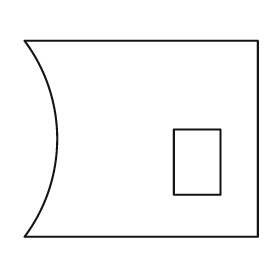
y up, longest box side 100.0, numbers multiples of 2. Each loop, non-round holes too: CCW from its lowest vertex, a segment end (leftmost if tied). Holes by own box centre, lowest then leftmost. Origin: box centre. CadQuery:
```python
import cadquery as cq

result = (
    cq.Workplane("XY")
    .moveTo(-50.0, -42.0)
    .lineTo(50.0, -42.0)
    .lineTo(50.0, 42.0)
    .lineTo(-50.0, 42.0)
    .threePointArc((-36.0, 0.0), (-50.0, -42.0))
    .close()
    .moveTo(14.0, -24.0)
    .lineTo(34.0, -24.0)
    .lineTo(34.0, 4.0)
    .lineTo(14.0, 4.0)
    .close()
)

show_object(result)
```